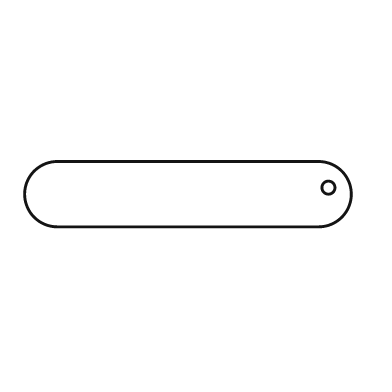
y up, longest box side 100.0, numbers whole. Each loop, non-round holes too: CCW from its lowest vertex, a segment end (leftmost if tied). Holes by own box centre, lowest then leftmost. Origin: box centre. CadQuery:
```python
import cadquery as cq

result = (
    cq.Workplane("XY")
    .moveTo(-40.0, -10.0)
    .lineTo(40.0, -10.0)
    .threePointArc((50.0, 0.0), (40.0, 10.0))
    .lineTo(-40.0, 10.0)
    .threePointArc((-50.0, 0.0), (-40.0, -10.0))
    .close()
    .moveTo(43.0, 2.0)
    .circle(2.0)
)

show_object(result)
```